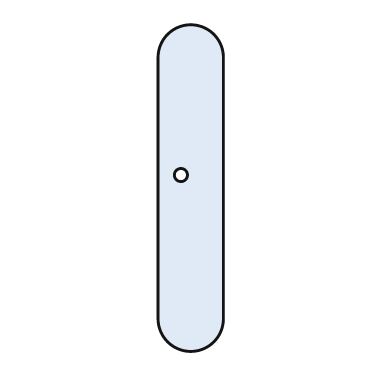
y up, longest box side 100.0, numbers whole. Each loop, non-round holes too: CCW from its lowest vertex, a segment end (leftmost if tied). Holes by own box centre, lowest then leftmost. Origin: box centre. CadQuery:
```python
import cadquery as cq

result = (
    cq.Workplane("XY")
    .moveTo(-10.0, -40.0)
    .threePointArc((0.0, -50.0), (10.0, -40.0))
    .lineTo(10.0, 40.0)
    .threePointArc((0.0, 50.0), (-10.0, 40.0))
    .close()
    .moveTo(-3.0, 4.0)
    .circle(2.0)
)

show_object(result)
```